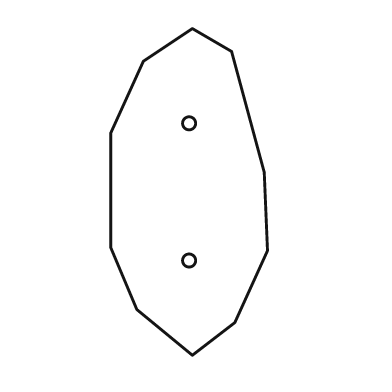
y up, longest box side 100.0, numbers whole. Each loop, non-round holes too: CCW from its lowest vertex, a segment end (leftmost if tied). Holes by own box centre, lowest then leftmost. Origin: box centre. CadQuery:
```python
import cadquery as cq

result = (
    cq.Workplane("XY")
    .moveTo(1.0, -50.0)
    .lineTo(14.0, -40.0)
    .lineTo(24.0, -18.0)
    .lineTo(23.0, 6.0)
    .lineTo(13.0, 43.0)
    .lineTo(1.0, 50.0)
    .lineTo(-14.0, 40.0)
    .lineTo(-24.0, 18.0)
    .lineTo(-24.0, -17.0)
    .lineTo(-16.0, -36.0)
    .close()
    .moveTo(0.0, -21.0)
    .circle(2.0)
    .moveTo(0.0, 21.0)
    .circle(2.0)
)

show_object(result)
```